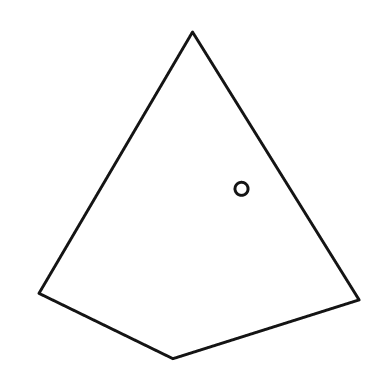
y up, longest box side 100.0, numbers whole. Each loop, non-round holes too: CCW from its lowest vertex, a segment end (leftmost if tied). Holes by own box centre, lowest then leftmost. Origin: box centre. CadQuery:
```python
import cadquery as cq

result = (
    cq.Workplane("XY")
    .moveTo(-8.0, -50.0)
    .lineTo(49.0, -32.0)
    .lineTo(-2.0, 50.0)
    .lineTo(-49.0, -30.0)
    .close()
    .moveTo(13.0, 2.0)
    .circle(2.0)
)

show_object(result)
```